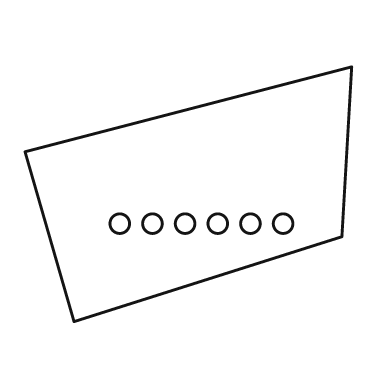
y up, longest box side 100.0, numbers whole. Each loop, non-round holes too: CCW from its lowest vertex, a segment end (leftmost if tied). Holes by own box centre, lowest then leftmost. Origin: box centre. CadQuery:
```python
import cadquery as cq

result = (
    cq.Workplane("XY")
    .moveTo(-35.0, -39.0)
    .lineTo(47.0, -13.0)
    .lineTo(50.0, 39.0)
    .lineTo(-50.0, 13.0)
    .close()
    .moveTo(-21.0, -9.0)
    .circle(3.0)
    .moveTo(-11.0, -9.0)
    .circle(3.0)
    .moveTo(-1.0, -9.0)
    .circle(3.0)
    .moveTo(9.0, -9.0)
    .circle(3.0)
    .moveTo(19.0, -9.0)
    .circle(3.0)
    .moveTo(29.0, -9.0)
    .circle(3.0)
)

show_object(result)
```